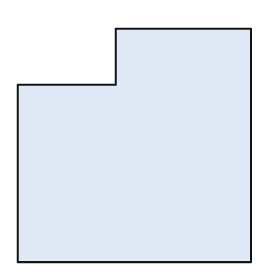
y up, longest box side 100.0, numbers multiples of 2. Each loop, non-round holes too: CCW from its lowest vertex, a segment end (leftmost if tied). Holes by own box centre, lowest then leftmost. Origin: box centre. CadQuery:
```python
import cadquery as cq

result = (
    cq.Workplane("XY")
    .moveTo(-50.0, -50.0)
    .lineTo(50.0, -50.0)
    .lineTo(50.0, 50.0)
    .lineTo(-8.0, 50.0)
    .lineTo(-8.0, 26.0)
    .lineTo(-50.0, 26.0)
    .close()
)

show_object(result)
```